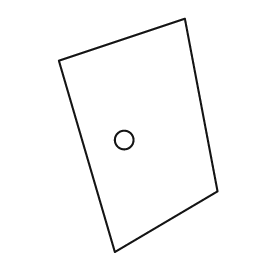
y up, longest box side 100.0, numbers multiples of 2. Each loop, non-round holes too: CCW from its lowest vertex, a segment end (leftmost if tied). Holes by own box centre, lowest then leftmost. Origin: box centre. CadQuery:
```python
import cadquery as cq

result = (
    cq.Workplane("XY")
    .moveTo(-10.0, -50.0)
    .lineTo(34.0, -24.0)
    .lineTo(20.0, 50.0)
    .lineTo(-34.0, 32.0)
    .close()
    .moveTo(-6.0, -2.0)
    .circle(4.0)
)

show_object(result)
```